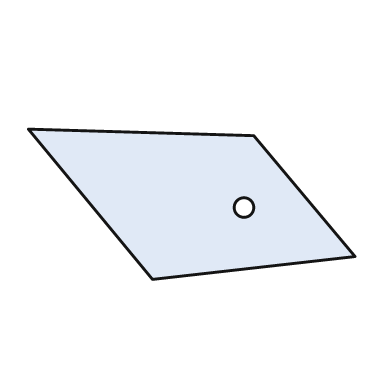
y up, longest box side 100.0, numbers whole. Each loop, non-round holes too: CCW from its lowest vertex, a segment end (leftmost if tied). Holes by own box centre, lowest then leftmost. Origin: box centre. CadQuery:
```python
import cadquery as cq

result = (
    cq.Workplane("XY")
    .moveTo(-12.0, -23.0)
    .lineTo(50.0, -16.0)
    .lineTo(19.0, 21.0)
    .lineTo(-50.0, 23.0)
    .close()
    .moveTo(16.0, -1.0)
    .circle(3.0)
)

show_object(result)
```